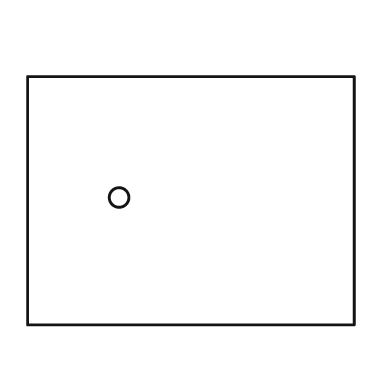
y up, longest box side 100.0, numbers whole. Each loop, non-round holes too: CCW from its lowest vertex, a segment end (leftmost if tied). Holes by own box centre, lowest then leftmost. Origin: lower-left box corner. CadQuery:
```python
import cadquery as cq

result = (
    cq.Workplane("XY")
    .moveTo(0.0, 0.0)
    .lineTo(100.0, 0.0)
    .lineTo(100.0, 76.0)
    .lineTo(0.0, 76.0)
    .close()
    .moveTo(28.0, 39.0)
    .circle(3.0)
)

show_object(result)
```